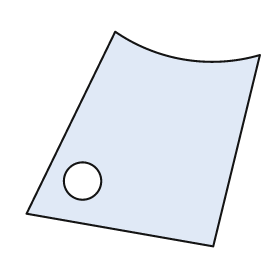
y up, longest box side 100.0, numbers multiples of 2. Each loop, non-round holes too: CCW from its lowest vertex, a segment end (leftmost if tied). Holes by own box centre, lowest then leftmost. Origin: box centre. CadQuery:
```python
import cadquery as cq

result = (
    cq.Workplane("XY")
    .moveTo(30.0, -46.0)
    .lineTo(50.0, 36.0)
    .threePointArc((18.0, 34.0), (-12.0, 46.0))
    .lineTo(-50.0, -32.0)
    .close()
    .moveTo(-26.0, -18.0)
    .circle(8.0)
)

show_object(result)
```